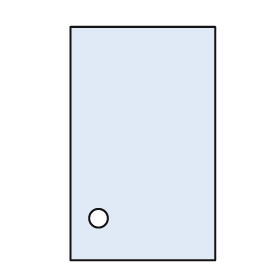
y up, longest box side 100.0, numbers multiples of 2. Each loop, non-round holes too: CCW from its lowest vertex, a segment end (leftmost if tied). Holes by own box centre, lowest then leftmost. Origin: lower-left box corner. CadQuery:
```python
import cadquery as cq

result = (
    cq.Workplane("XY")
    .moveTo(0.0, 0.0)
    .lineTo(62.0, 0.0)
    .lineTo(62.0, 100.0)
    .lineTo(0.0, 100.0)
    .close()
    .moveTo(12.0, 18.0)
    .circle(4.0)
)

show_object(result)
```